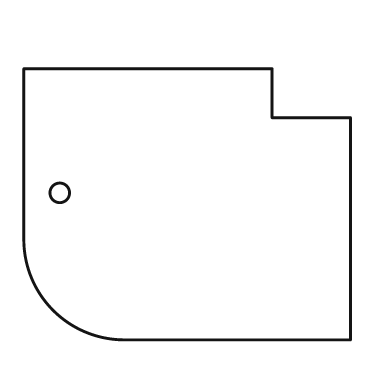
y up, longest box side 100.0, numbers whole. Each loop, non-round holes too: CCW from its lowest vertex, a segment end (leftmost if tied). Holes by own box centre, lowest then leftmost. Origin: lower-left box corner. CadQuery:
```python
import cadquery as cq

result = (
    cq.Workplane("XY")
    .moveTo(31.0, 0.0)
    .lineTo(100.0, 0.0)
    .lineTo(100.0, 68.0)
    .lineTo(76.0, 68.0)
    .lineTo(76.0, 83.0)
    .lineTo(0.0, 83.0)
    .lineTo(0.0, 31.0)
    .threePointArc((9.0, 9.0), (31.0, 0.0))
    .close()
    .moveTo(11.0, 45.0)
    .circle(3.0)
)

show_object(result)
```